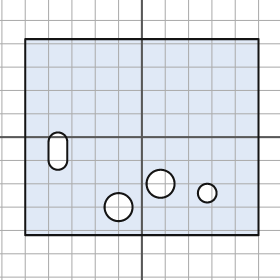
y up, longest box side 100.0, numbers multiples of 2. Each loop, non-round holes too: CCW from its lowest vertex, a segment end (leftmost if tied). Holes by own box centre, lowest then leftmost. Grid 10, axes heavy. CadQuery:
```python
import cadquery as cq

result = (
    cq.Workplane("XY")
    .moveTo(-50.0, -42.0)
    .lineTo(50.0, -42.0)
    .lineTo(50.0, 42.0)
    .lineTo(-50.0, 42.0)
    .close()
    .moveTo(-10.0, -30.0)
    .circle(6.0)
    .moveTo(28.0, -24.0)
    .circle(4.0)
    .moveTo(8.0, -20.0)
    .circle(6.0)
    .moveTo(-40.0, -10.0)
    .threePointArc((-36.0, -14.0), (-32.0, -10.0))
    .lineTo(-32.0, -2.0)
    .threePointArc((-36.0, 2.0), (-40.0, -2.0))
    .close()
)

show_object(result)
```